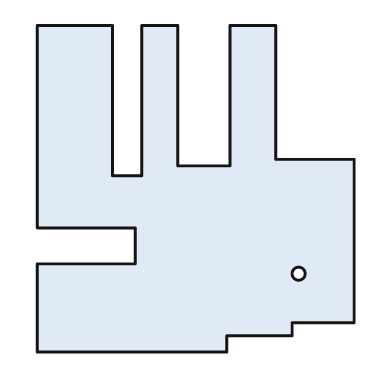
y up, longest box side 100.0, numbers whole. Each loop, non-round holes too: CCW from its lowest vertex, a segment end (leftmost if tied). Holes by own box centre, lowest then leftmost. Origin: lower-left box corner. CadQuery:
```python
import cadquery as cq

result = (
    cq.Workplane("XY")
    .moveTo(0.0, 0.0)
    .lineTo(58.0, 0.0)
    .lineTo(58.0, 5.0)
    .lineTo(78.0, 5.0)
    .lineTo(78.0, 9.0)
    .lineTo(97.0, 9.0)
    .lineTo(97.0, 59.0)
    .lineTo(73.0, 59.0)
    .lineTo(73.0, 100.0)
    .lineTo(59.0, 100.0)
    .lineTo(59.0, 57.0)
    .lineTo(43.0, 57.0)
    .lineTo(43.0, 100.0)
    .lineTo(32.0, 100.0)
    .lineTo(32.0, 54.0)
    .lineTo(23.0, 54.0)
    .lineTo(23.0, 100.0)
    .lineTo(0.0, 100.0)
    .lineTo(0.0, 38.0)
    .lineTo(30.0, 38.0)
    .lineTo(30.0, 27.0)
    .lineTo(0.0, 27.0)
    .close()
    .moveTo(80.0, 24.0)
    .circle(2.0)
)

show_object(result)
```